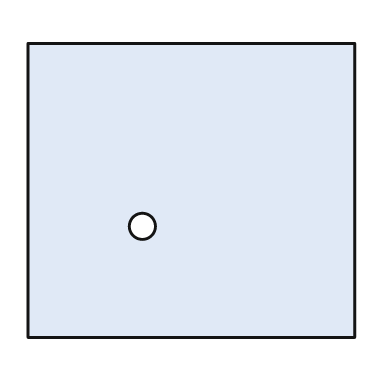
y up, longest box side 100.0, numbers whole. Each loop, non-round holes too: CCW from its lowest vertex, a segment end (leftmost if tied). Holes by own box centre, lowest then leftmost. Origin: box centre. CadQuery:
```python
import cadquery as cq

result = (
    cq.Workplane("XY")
    .moveTo(-50.0, -45.0)
    .lineTo(50.0, -45.0)
    .lineTo(50.0, 45.0)
    .lineTo(-50.0, 45.0)
    .close()
    .moveTo(-15.0, -11.0)
    .circle(4.0)
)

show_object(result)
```